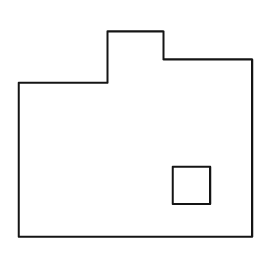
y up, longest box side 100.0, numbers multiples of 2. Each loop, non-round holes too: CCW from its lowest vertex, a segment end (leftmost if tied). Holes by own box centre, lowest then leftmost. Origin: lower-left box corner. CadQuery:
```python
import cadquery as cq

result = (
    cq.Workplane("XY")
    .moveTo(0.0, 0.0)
    .lineTo(100.0, 0.0)
    .lineTo(100.0, 76.0)
    .lineTo(62.0, 76.0)
    .lineTo(62.0, 88.0)
    .lineTo(38.0, 88.0)
    .lineTo(38.0, 66.0)
    .lineTo(0.0, 66.0)
    .close()
    .moveTo(66.0, 14.0)
    .lineTo(82.0, 14.0)
    .lineTo(82.0, 30.0)
    .lineTo(66.0, 30.0)
    .close()
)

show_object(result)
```